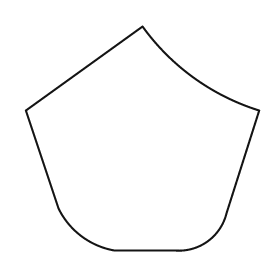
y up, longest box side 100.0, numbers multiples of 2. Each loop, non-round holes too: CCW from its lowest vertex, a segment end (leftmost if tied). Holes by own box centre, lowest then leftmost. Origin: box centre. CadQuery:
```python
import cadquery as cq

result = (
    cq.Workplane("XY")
    .moveTo(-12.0, -48.0)
    .lineTo(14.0, -48.0)
    .threePointArc((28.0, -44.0), (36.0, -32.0))
    .lineTo(50.0, 12.0)
    .threePointArc((22.0, 26.0), (0.0, 48.0))
    .lineTo(-50.0, 12.0)
    .lineTo(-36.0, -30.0)
    .threePointArc((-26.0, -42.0), (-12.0, -48.0))
    .close()
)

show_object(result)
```